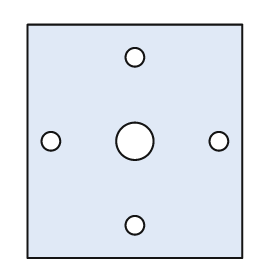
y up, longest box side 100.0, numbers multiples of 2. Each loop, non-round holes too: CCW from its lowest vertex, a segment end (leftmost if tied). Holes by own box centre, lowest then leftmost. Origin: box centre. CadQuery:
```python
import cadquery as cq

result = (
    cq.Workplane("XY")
    .moveTo(-46.0, -50.0)
    .lineTo(46.0, -50.0)
    .lineTo(46.0, 50.0)
    .lineTo(-46.0, 50.0)
    .close()
    .moveTo(0.0, -36.0)
    .circle(4.0)
    .moveTo(-36.0, 0.0)
    .circle(4.0)
    .moveTo(0.0, 0.0)
    .circle(8.0)
    .moveTo(36.0, 0.0)
    .circle(4.0)
    .moveTo(0.0, 36.0)
    .circle(4.0)
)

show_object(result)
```